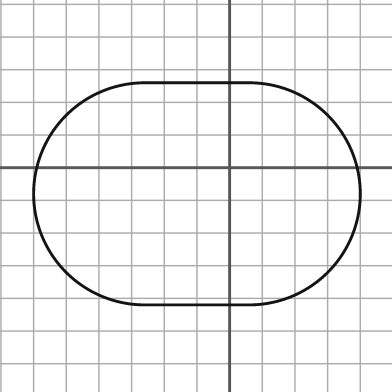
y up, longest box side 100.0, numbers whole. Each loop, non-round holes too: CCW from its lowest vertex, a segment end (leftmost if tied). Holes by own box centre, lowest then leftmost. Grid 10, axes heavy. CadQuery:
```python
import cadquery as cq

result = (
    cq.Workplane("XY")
    .moveTo(-26.0, -42.0)
    .lineTo(6.0, -42.0)
    .threePointArc((40.0, -8.0), (6.0, 26.0))
    .lineTo(-26.0, 26.0)
    .threePointArc((-60.0, -8.0), (-26.0, -42.0))
    .close()
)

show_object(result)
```